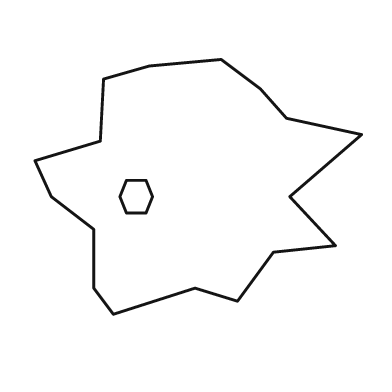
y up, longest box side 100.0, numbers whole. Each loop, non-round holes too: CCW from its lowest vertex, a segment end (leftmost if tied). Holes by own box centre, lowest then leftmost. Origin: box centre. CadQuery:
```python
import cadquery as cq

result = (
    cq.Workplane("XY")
    .moveTo(-26.0, -39.0)
    .lineTo(-1.0, -31.0)
    .lineTo(12.0, -35.0)
    .lineTo(23.0, -20.0)
    .lineTo(42.0, -18.0)
    .lineTo(28.0, -3.0)
    .lineTo(50.0, 16.0)
    .lineTo(27.0, 21.0)
    .lineTo(19.0, 30.0)
    .lineTo(7.0, 39.0)
    .lineTo(-15.0, 37.0)
    .lineTo(-29.0, 33.0)
    .lineTo(-30.0, 14.0)
    .lineTo(-50.0, 8.0)
    .lineTo(-45.0, -3.0)
    .lineTo(-32.0, -13.0)
    .lineTo(-32.0, -31.0)
    .close()
    .moveTo(-22.0, -8.0)
    .lineTo(-16.0, -8.0)
    .lineTo(-14.0, -3.0)
    .lineTo(-16.0, 2.0)
    .lineTo(-22.0, 2.0)
    .lineTo(-24.0, -3.0)
    .close()
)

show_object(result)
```